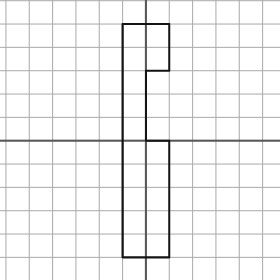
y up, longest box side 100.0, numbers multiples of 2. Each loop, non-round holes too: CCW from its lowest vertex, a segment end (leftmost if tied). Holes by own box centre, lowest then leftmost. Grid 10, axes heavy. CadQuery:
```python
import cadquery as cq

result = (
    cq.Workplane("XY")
    .moveTo(-10.0, -50.0)
    .lineTo(10.0, -50.0)
    .lineTo(10.0, 0.0)
    .lineTo(0.0, 0.0)
    .lineTo(0.0, 30.0)
    .lineTo(10.0, 30.0)
    .lineTo(10.0, 50.0)
    .lineTo(-10.0, 50.0)
    .close()
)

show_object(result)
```